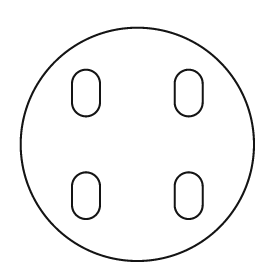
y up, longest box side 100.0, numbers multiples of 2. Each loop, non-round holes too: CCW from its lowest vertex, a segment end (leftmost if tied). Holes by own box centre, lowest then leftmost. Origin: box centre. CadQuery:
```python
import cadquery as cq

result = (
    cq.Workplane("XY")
    .moveTo(0.0, 0.0)
    .circle(50.0)
    .moveTo(-28.0, -26.0)
    .threePointArc((-22.0, -32.0), (-16.0, -26.0))
    .lineTo(-16.0, -18.0)
    .threePointArc((-22.0, -12.0), (-28.0, -18.0))
    .close()
    .moveTo(16.0, -26.0)
    .threePointArc((22.0, -32.0), (28.0, -26.0))
    .lineTo(28.0, -18.0)
    .threePointArc((22.0, -12.0), (16.0, -18.0))
    .close()
    .moveTo(-28.0, 18.0)
    .threePointArc((-22.0, 12.0), (-16.0, 18.0))
    .lineTo(-16.0, 26.0)
    .threePointArc((-22.0, 32.0), (-28.0, 26.0))
    .close()
    .moveTo(16.0, 18.0)
    .threePointArc((22.0, 12.0), (28.0, 18.0))
    .lineTo(28.0, 26.0)
    .threePointArc((22.0, 32.0), (16.0, 26.0))
    .close()
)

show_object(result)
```